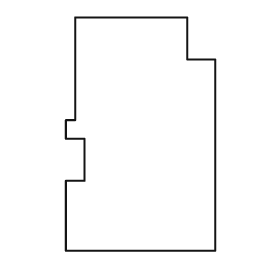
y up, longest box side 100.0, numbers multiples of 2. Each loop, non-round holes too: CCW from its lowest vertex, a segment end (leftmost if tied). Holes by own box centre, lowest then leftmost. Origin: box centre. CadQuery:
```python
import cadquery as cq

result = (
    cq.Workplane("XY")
    .moveTo(-32.0, -50.0)
    .lineTo(32.0, -50.0)
    .lineTo(32.0, 32.0)
    .lineTo(20.0, 32.0)
    .lineTo(20.0, 50.0)
    .lineTo(-28.0, 50.0)
    .lineTo(-28.0, 6.0)
    .lineTo(-32.0, 6.0)
    .lineTo(-32.0, -2.0)
    .lineTo(-24.0, -2.0)
    .lineTo(-24.0, -20.0)
    .lineTo(-32.0, -20.0)
    .close()
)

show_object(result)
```